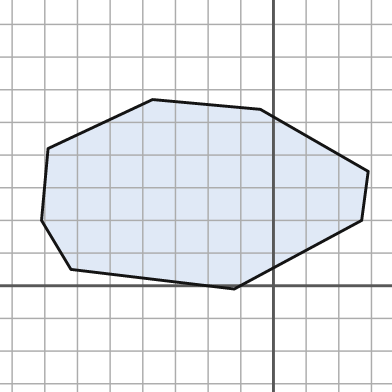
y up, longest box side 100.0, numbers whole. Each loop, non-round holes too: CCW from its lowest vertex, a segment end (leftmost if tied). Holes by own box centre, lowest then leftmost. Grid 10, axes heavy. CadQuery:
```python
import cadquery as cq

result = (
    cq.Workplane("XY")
    .moveTo(-12.0, -1.0)
    .lineTo(27.0, 20.0)
    .lineTo(29.0, 35.0)
    .lineTo(-4.0, 54.0)
    .lineTo(-37.0, 57.0)
    .lineTo(-69.0, 42.0)
    .lineTo(-71.0, 20.0)
    .lineTo(-62.0, 5.0)
    .close()
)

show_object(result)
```